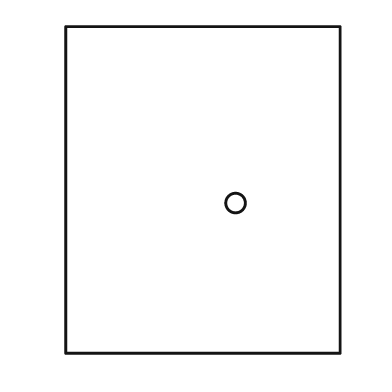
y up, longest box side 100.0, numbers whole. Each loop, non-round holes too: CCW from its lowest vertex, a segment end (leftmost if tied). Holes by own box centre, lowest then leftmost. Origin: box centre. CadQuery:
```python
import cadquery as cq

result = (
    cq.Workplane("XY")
    .moveTo(-42.0, -50.0)
    .lineTo(42.0, -50.0)
    .lineTo(42.0, 50.0)
    .lineTo(-42.0, 50.0)
    .close()
    .moveTo(10.0, -4.0)
    .circle(3.0)
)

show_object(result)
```